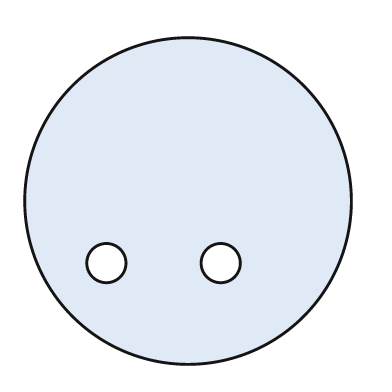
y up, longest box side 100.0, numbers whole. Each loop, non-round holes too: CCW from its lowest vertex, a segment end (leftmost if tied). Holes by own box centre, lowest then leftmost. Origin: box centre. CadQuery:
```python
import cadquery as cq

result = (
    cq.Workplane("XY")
    .moveTo(0.0, 0.0)
    .circle(50.0)
    .moveTo(-25.0, -19.0)
    .circle(6.0)
    .moveTo(10.0, -19.0)
    .circle(6.0)
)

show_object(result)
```